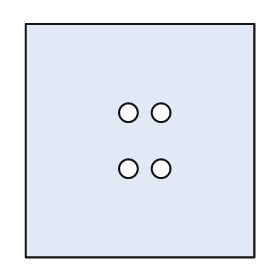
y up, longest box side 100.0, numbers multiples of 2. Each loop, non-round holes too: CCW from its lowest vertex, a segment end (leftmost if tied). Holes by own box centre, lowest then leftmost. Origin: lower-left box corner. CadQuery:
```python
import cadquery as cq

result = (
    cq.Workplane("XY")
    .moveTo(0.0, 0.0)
    .lineTo(98.0, 0.0)
    .lineTo(98.0, 100.0)
    .lineTo(0.0, 100.0)
    .close()
    .moveTo(44.0, 38.0)
    .circle(4.0)
    .moveTo(58.0, 38.0)
    .circle(4.0)
    .moveTo(44.0, 62.0)
    .circle(4.0)
    .moveTo(58.0, 62.0)
    .circle(4.0)
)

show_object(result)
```